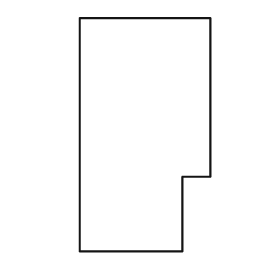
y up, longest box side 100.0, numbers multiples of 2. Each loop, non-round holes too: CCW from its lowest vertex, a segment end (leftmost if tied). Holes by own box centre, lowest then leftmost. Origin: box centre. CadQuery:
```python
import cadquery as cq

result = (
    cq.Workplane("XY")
    .moveTo(-28.0, -50.0)
    .lineTo(16.0, -50.0)
    .lineTo(16.0, -18.0)
    .lineTo(28.0, -18.0)
    .lineTo(28.0, 50.0)
    .lineTo(-28.0, 50.0)
    .close()
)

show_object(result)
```